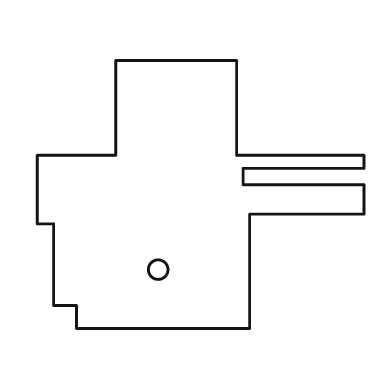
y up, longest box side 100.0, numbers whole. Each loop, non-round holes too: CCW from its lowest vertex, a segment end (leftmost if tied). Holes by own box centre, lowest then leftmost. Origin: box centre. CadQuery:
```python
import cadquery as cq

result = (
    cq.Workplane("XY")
    .moveTo(-38.0, -41.0)
    .lineTo(15.0, -41.0)
    .lineTo(15.0, -6.0)
    .lineTo(50.0, -6.0)
    .lineTo(50.0, 3.0)
    .lineTo(13.0, 3.0)
    .lineTo(13.0, 8.0)
    .lineTo(50.0, 8.0)
    .lineTo(50.0, 12.0)
    .lineTo(11.0, 12.0)
    .lineTo(11.0, 41.0)
    .lineTo(-26.0, 41.0)
    .lineTo(-26.0, 12.0)
    .lineTo(-50.0, 12.0)
    .lineTo(-50.0, -9.0)
    .lineTo(-45.0, -9.0)
    .lineTo(-45.0, -34.0)
    .lineTo(-38.0, -34.0)
    .close()
    .moveTo(-13.0, -23.0)
    .circle(3.0)
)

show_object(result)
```